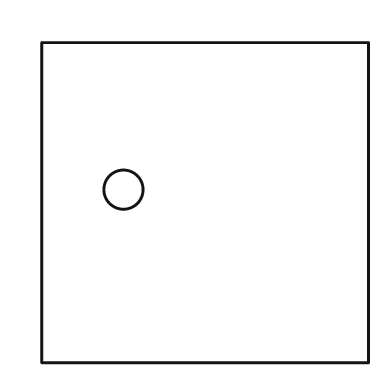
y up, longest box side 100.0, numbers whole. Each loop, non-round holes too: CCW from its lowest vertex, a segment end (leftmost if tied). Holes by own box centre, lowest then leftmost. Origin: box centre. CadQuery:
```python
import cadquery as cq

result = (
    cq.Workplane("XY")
    .moveTo(-50.0, -49.0)
    .lineTo(50.0, -49.0)
    .lineTo(50.0, 49.0)
    .lineTo(-50.0, 49.0)
    .close()
    .moveTo(-25.0, 4.0)
    .circle(6.0)
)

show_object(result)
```